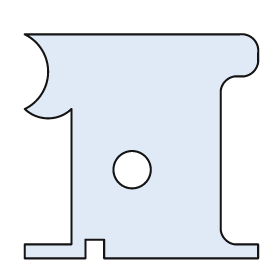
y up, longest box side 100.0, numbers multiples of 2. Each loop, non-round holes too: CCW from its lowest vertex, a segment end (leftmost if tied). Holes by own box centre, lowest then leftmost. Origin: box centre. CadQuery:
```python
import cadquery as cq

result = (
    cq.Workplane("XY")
    .moveTo(-50.0, -48.0)
    .lineTo(-24.0, -48.0)
    .lineTo(-24.0, -40.0)
    .lineTo(-16.0, -40.0)
    .lineTo(-16.0, -48.0)
    .lineTo(50.0, -48.0)
    .lineTo(50.0, -42.0)
    .lineTo(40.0, -42.0)
    .threePointArc((36.0, -40.0), (34.0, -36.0))
    .lineTo(34.0, 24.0)
    .threePointArc((36.0, 28.0), (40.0, 30.0))
    .lineTo(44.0, 30.0)
    .threePointArc((48.0, 32.0), (50.0, 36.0))
    .lineTo(50.0, 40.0)
    .threePointArc((48.0, 46.0), (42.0, 48.0))
    .lineTo(-50.0, 48.0)
    .threePointArc((-40.0, 32.0), (-50.0, 16.0))
    .threePointArc((-40.0, 12.0), (-30.0, 16.0))
    .lineTo(-30.0, -42.0)
    .lineTo(-50.0, -42.0)
    .close()
    .moveTo(-4.0, -10.0)
    .circle(8.0)
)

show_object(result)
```